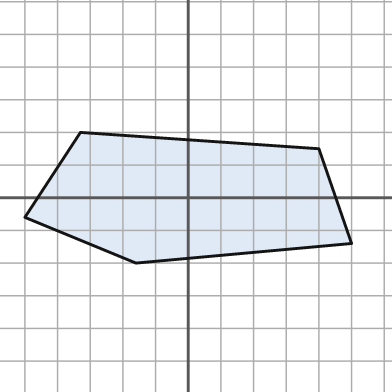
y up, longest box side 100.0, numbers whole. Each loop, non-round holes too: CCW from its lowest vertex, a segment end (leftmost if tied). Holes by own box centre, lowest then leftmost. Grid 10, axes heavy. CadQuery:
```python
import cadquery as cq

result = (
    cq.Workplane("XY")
    .moveTo(-16.0, -20.0)
    .lineTo(50.0, -14.0)
    .lineTo(40.0, 15.0)
    .lineTo(-33.0, 20.0)
    .lineTo(-50.0, -6.0)
    .close()
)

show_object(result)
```